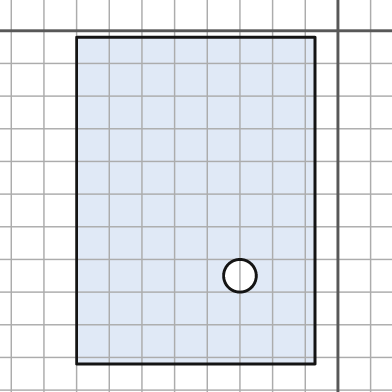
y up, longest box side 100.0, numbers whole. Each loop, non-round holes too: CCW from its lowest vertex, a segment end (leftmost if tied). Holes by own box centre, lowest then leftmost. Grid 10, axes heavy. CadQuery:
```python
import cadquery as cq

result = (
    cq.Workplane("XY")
    .moveTo(-80.0, -102.0)
    .lineTo(-7.0, -102.0)
    .lineTo(-7.0, -2.0)
    .lineTo(-80.0, -2.0)
    .close()
    .moveTo(-30.0, -75.0)
    .circle(5.0)
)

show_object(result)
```